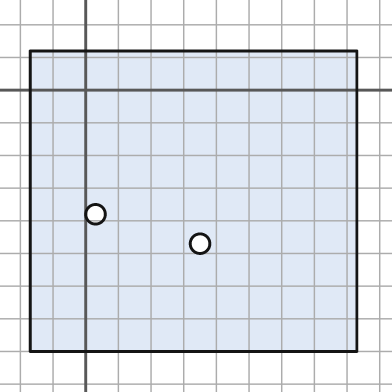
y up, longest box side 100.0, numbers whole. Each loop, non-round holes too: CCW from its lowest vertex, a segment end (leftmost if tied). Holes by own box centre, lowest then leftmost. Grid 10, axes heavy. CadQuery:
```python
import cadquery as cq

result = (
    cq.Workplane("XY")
    .moveTo(-17.0, -80.0)
    .lineTo(83.0, -80.0)
    .lineTo(83.0, 12.0)
    .lineTo(-17.0, 12.0)
    .close()
    .moveTo(35.0, -47.0)
    .circle(3.0)
    .moveTo(3.0, -38.0)
    .circle(3.0)
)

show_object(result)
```